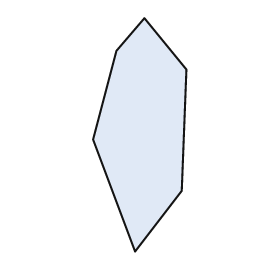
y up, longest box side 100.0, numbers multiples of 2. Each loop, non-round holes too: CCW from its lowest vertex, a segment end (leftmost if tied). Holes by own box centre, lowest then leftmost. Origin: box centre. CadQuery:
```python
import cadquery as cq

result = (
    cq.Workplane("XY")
    .moveTo(-2.0, -50.0)
    .lineTo(18.0, -24.0)
    .lineTo(20.0, 28.0)
    .lineTo(2.0, 50.0)
    .lineTo(-10.0, 36.0)
    .lineTo(-20.0, -2.0)
    .close()
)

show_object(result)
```